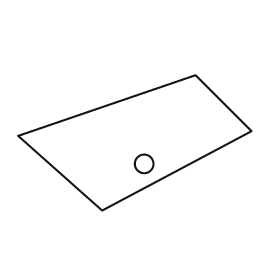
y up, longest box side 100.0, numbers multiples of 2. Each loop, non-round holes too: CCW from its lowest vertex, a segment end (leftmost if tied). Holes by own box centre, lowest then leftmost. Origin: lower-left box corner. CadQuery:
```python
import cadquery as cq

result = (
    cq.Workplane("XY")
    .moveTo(36.0, 0.0)
    .lineTo(100.0, 34.0)
    .lineTo(76.0, 58.0)
    .lineTo(0.0, 32.0)
    .close()
    .moveTo(54.0, 20.0)
    .circle(4.0)
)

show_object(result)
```